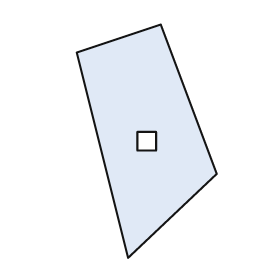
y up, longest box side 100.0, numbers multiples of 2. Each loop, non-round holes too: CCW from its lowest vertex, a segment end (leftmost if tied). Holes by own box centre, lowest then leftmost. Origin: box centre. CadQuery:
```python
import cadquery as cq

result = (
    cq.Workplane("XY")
    .moveTo(-8.0, -50.0)
    .lineTo(30.0, -14.0)
    .lineTo(6.0, 50.0)
    .lineTo(-30.0, 38.0)
    .close()
    .moveTo(-4.0, -4.0)
    .lineTo(4.0, -4.0)
    .lineTo(4.0, 4.0)
    .lineTo(-4.0, 4.0)
    .close()
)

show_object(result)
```